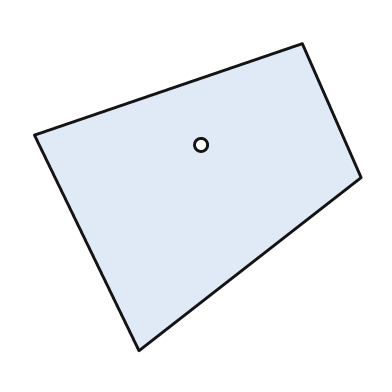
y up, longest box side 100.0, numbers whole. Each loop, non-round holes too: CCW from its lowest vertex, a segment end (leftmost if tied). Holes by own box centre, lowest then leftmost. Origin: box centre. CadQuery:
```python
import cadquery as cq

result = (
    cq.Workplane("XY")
    .moveTo(-18.0, -47.0)
    .lineTo(50.0, 6.0)
    .lineTo(32.0, 47.0)
    .lineTo(-50.0, 19.0)
    .close()
    .moveTo(1.0, 16.0)
    .circle(2.0)
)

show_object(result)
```